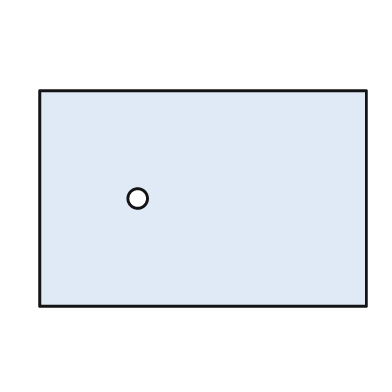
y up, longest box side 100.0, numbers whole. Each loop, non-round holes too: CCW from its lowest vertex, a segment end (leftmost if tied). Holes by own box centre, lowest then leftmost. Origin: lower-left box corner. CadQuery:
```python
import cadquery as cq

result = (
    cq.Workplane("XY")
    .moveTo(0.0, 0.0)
    .lineTo(100.0, 0.0)
    .lineTo(100.0, 66.0)
    .lineTo(0.0, 66.0)
    .close()
    .moveTo(30.0, 33.0)
    .circle(3.0)
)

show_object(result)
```